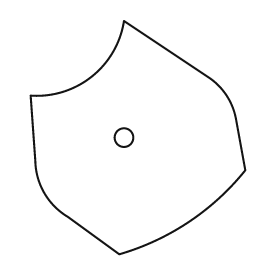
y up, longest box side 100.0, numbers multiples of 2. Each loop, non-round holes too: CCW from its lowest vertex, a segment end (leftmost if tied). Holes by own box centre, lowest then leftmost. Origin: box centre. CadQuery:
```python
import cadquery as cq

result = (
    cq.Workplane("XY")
    .moveTo(-8.0, -50.0)
    .threePointArc((22.0, -36.0), (46.0, -14.0))
    .lineTo(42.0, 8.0)
    .threePointArc((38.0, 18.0), (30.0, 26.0))
    .lineTo(-6.0, 50.0)
    .threePointArc((-20.0, 26.0), (-46.0, 18.0))
    .lineTo(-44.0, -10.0)
    .threePointArc((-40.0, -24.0), (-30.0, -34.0))
    .close()
    .moveTo(-6.0, 0.0)
    .circle(4.0)
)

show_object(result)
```